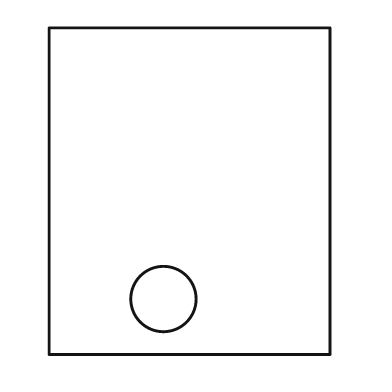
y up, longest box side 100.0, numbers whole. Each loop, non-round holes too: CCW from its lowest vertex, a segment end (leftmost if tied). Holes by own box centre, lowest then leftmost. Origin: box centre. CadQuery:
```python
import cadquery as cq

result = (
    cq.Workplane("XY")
    .moveTo(-43.0, -50.0)
    .lineTo(43.0, -50.0)
    .lineTo(43.0, 50.0)
    .lineTo(-43.0, 50.0)
    .close()
    .moveTo(-8.0, -33.0)
    .circle(10.0)
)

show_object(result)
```